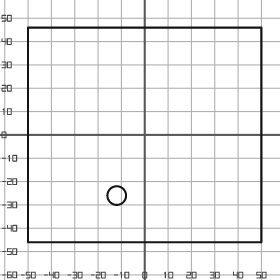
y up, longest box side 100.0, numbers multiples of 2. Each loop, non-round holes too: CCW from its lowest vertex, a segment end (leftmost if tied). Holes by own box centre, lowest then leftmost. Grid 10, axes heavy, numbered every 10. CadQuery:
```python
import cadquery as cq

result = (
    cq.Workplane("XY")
    .moveTo(-50.0, -46.0)
    .lineTo(50.0, -46.0)
    .lineTo(50.0, 46.0)
    .lineTo(-50.0, 46.0)
    .close()
    .moveTo(-12.0, -26.0)
    .circle(4.0)
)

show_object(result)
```